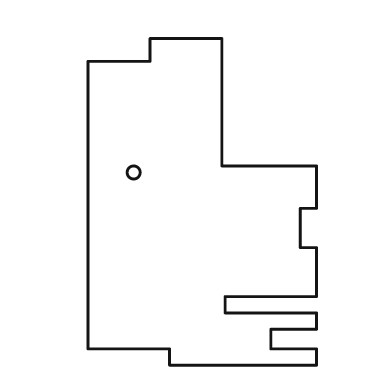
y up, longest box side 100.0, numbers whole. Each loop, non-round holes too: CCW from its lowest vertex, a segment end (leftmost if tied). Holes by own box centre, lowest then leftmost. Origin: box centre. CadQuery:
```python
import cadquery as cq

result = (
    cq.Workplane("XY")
    .moveTo(-10.0, -50.0)
    .lineTo(35.0, -50.0)
    .lineTo(35.0, -45.0)
    .lineTo(21.0, -45.0)
    .lineTo(21.0, -39.0)
    .lineTo(35.0, -39.0)
    .lineTo(35.0, -34.0)
    .lineTo(7.0, -34.0)
    .lineTo(7.0, -29.0)
    .lineTo(35.0, -29.0)
    .lineTo(35.0, -14.0)
    .lineTo(30.0, -14.0)
    .lineTo(30.0, -2.0)
    .lineTo(35.0, -2.0)
    .lineTo(35.0, 11.0)
    .lineTo(6.0, 11.0)
    .lineTo(6.0, 50.0)
    .lineTo(-16.0, 50.0)
    .lineTo(-16.0, 43.0)
    .lineTo(-35.0, 43.0)
    .lineTo(-35.0, -45.0)
    .lineTo(-10.0, -45.0)
    .close()
    .moveTo(-21.0, 9.0)
    .circle(2.0)
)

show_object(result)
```